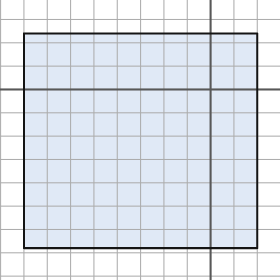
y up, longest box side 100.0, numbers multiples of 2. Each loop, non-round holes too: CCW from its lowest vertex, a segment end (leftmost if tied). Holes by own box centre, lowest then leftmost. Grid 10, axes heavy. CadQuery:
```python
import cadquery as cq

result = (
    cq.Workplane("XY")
    .moveTo(-80.0, -68.0)
    .lineTo(20.0, -68.0)
    .lineTo(20.0, 24.0)
    .lineTo(-80.0, 24.0)
    .close()
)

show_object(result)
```